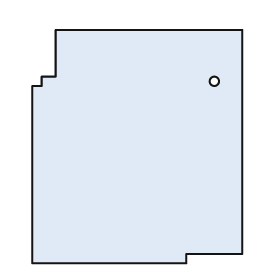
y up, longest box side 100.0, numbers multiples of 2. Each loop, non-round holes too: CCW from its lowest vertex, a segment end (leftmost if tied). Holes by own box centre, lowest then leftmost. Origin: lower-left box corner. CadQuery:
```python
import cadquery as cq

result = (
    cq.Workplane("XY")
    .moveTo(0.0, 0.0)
    .lineTo(66.0, 0.0)
    .lineTo(66.0, 4.0)
    .lineTo(90.0, 4.0)
    .lineTo(90.0, 100.0)
    .lineTo(10.0, 100.0)
    .lineTo(10.0, 80.0)
    .lineTo(4.0, 80.0)
    .lineTo(4.0, 76.0)
    .lineTo(0.0, 76.0)
    .close()
    .moveTo(78.0, 78.0)
    .circle(2.0)
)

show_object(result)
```